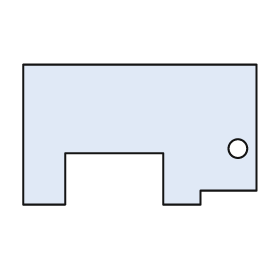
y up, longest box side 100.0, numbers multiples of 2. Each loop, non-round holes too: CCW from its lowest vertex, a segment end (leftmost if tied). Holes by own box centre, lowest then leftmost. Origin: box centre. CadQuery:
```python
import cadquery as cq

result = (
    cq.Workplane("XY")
    .moveTo(-50.0, -30.0)
    .lineTo(-32.0, -30.0)
    .lineTo(-32.0, -8.0)
    .lineTo(10.0, -8.0)
    .lineTo(10.0, -30.0)
    .lineTo(26.0, -30.0)
    .lineTo(26.0, -24.0)
    .lineTo(50.0, -24.0)
    .lineTo(50.0, 30.0)
    .lineTo(-50.0, 30.0)
    .close()
    .moveTo(42.0, -6.0)
    .circle(4.0)
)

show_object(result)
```